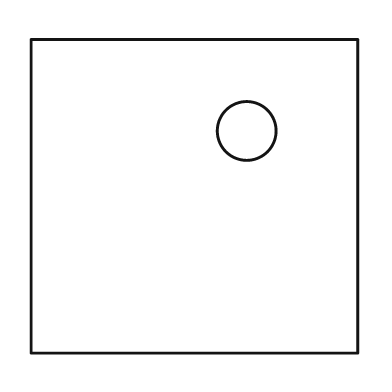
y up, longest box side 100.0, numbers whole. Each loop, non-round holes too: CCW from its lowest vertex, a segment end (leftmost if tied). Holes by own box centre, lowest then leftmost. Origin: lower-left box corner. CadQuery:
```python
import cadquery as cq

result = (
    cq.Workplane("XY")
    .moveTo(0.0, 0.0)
    .lineTo(100.0, 0.0)
    .lineTo(100.0, 96.0)
    .lineTo(0.0, 96.0)
    .close()
    .moveTo(66.0, 68.0)
    .circle(9.0)
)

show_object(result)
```